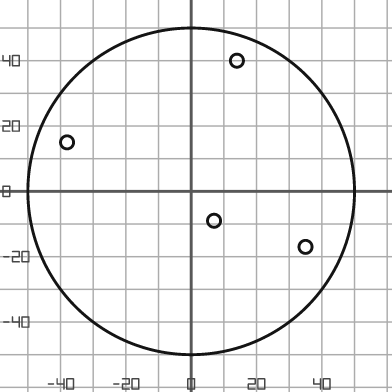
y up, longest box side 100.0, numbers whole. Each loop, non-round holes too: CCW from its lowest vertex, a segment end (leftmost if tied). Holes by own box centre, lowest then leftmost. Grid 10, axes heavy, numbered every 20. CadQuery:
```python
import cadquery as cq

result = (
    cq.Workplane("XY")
    .moveTo(0.0, 0.0)
    .circle(50.0)
    .moveTo(35.0, -17.0)
    .circle(2.0)
    .moveTo(7.0, -9.0)
    .circle(2.0)
    .moveTo(-38.0, 15.0)
    .circle(2.0)
    .moveTo(14.0, 40.0)
    .circle(2.0)
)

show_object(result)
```